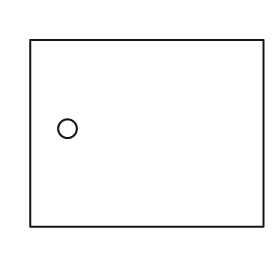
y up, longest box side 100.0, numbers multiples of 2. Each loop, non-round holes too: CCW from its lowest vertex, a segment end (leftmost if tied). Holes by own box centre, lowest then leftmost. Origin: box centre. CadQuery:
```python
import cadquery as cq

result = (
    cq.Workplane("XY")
    .moveTo(-50.0, -40.0)
    .lineTo(50.0, -40.0)
    .lineTo(50.0, 40.0)
    .lineTo(-50.0, 40.0)
    .close()
    .moveTo(-34.0, 2.0)
    .circle(4.0)
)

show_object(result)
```